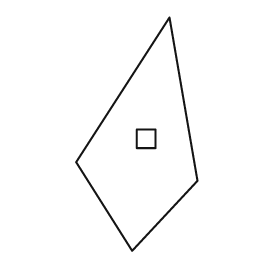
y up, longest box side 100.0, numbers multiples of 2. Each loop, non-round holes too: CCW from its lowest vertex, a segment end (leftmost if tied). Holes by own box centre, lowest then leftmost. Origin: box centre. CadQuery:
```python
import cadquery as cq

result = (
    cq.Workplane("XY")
    .moveTo(-2.0, -50.0)
    .lineTo(26.0, -20.0)
    .lineTo(14.0, 50.0)
    .lineTo(-26.0, -12.0)
    .close()
    .moveTo(0.0, -6.0)
    .lineTo(8.0, -6.0)
    .lineTo(8.0, 2.0)
    .lineTo(0.0, 2.0)
    .close()
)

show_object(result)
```